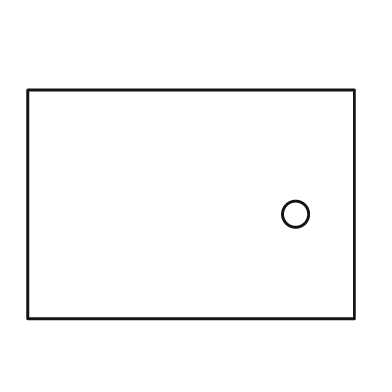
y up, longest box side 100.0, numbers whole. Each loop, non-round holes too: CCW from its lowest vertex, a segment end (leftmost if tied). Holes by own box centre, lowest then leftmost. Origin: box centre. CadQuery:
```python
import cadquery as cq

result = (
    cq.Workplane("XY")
    .moveTo(-50.0, -35.0)
    .lineTo(50.0, -35.0)
    .lineTo(50.0, 35.0)
    .lineTo(-50.0, 35.0)
    .close()
    .moveTo(32.0, -3.0)
    .circle(4.0)
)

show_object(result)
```